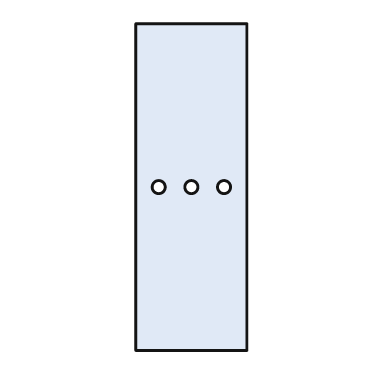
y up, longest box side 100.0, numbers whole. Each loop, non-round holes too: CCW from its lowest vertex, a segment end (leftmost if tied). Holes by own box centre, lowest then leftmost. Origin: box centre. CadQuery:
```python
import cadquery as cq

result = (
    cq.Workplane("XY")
    .moveTo(-17.0, -50.0)
    .lineTo(17.0, -50.0)
    .lineTo(17.0, 50.0)
    .lineTo(-17.0, 50.0)
    .close()
    .moveTo(-10.0, 0.0)
    .circle(2.0)
    .moveTo(0.0, 0.0)
    .circle(2.0)
    .moveTo(10.0, 0.0)
    .circle(2.0)
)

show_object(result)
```